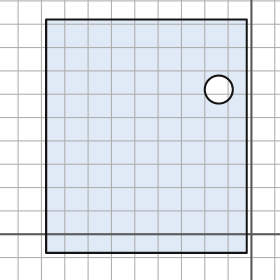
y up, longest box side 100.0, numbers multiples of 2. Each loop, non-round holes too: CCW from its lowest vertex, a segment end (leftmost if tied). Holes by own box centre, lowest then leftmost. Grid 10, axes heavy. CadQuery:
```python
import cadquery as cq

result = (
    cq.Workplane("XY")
    .moveTo(-88.0, -8.0)
    .lineTo(-2.0, -8.0)
    .lineTo(-2.0, 92.0)
    .lineTo(-88.0, 92.0)
    .close()
    .moveTo(-14.0, 62.0)
    .circle(6.0)
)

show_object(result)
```